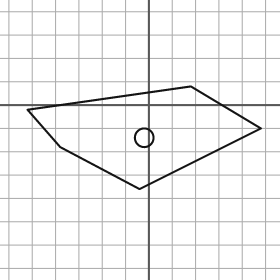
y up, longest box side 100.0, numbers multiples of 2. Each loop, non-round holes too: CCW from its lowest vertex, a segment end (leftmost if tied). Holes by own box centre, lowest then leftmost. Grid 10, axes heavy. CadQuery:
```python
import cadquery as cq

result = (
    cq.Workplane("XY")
    .moveTo(-4.0, -36.0)
    .lineTo(48.0, -10.0)
    .lineTo(18.0, 8.0)
    .lineTo(-52.0, -2.0)
    .lineTo(-38.0, -18.0)
    .close()
    .moveTo(-2.0, -14.0)
    .circle(4.0)
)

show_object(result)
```